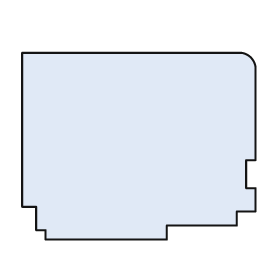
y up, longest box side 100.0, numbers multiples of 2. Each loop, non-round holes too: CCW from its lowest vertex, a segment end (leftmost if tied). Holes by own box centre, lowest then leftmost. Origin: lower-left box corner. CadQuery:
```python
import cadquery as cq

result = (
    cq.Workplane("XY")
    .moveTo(10.0, 0.0)
    .lineTo(62.0, 0.0)
    .lineTo(62.0, 6.0)
    .lineTo(92.0, 6.0)
    .lineTo(92.0, 12.0)
    .lineTo(100.0, 12.0)
    .lineTo(100.0, 22.0)
    .lineTo(96.0, 22.0)
    .lineTo(96.0, 34.0)
    .lineTo(100.0, 34.0)
    .lineTo(100.0, 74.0)
    .threePointArc((98.0, 78.0), (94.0, 80.0))
    .lineTo(0.0, 80.0)
    .lineTo(0.0, 14.0)
    .lineTo(6.0, 14.0)
    .lineTo(6.0, 4.0)
    .lineTo(10.0, 4.0)
    .close()
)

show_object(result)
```